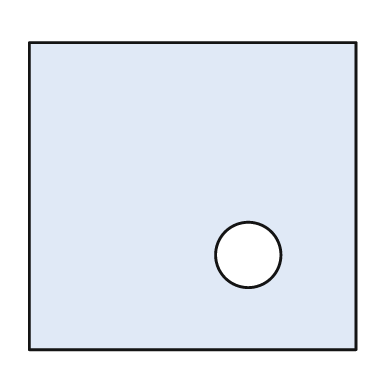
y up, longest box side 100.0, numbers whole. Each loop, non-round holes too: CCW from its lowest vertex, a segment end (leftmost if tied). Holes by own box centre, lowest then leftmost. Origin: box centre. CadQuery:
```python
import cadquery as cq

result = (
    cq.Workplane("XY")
    .moveTo(-50.0, -47.0)
    .lineTo(50.0, -47.0)
    .lineTo(50.0, 47.0)
    .lineTo(-50.0, 47.0)
    .close()
    .moveTo(17.0, -18.0)
    .circle(10.0)
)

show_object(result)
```